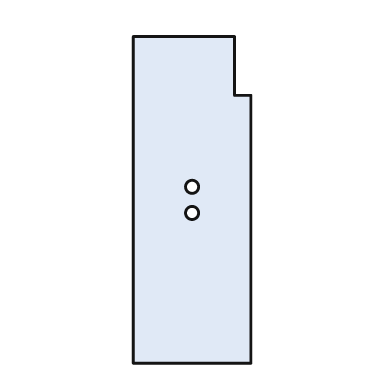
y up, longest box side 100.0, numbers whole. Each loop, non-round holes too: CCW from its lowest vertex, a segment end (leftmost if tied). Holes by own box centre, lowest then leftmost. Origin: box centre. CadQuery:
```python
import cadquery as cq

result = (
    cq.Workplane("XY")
    .moveTo(-18.0, -50.0)
    .lineTo(18.0, -50.0)
    .lineTo(18.0, 32.0)
    .lineTo(13.0, 32.0)
    .lineTo(13.0, 50.0)
    .lineTo(-18.0, 50.0)
    .close()
    .moveTo(0.0, -4.0)
    .circle(2.0)
    .moveTo(0.0, 4.0)
    .circle(2.0)
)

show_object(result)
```